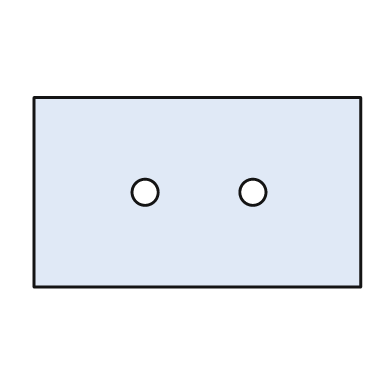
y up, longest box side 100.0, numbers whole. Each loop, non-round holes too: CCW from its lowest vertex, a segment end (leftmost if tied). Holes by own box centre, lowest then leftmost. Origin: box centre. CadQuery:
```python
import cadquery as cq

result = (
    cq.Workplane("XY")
    .moveTo(-50.0, -29.0)
    .lineTo(50.0, -29.0)
    .lineTo(50.0, 29.0)
    .lineTo(-50.0, 29.0)
    .close()
    .moveTo(-16.0, 0.0)
    .circle(4.0)
    .moveTo(17.0, 0.0)
    .circle(4.0)
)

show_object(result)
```